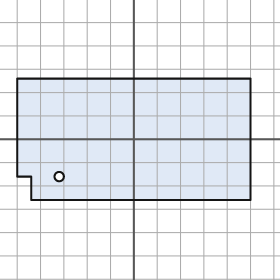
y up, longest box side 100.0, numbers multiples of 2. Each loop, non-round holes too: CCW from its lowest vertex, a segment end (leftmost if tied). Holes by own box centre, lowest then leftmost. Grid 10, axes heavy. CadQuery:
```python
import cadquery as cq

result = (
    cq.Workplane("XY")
    .moveTo(-44.0, -26.0)
    .lineTo(50.0, -26.0)
    .lineTo(50.0, 26.0)
    .lineTo(-50.0, 26.0)
    .lineTo(-50.0, -16.0)
    .lineTo(-44.0, -16.0)
    .close()
    .moveTo(-32.0, -16.0)
    .circle(2.0)
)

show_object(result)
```